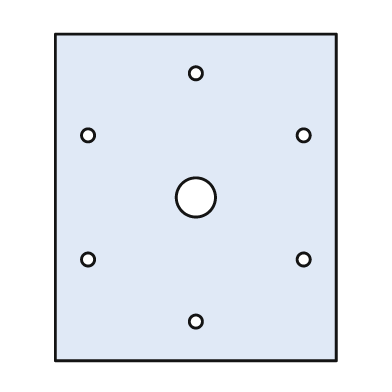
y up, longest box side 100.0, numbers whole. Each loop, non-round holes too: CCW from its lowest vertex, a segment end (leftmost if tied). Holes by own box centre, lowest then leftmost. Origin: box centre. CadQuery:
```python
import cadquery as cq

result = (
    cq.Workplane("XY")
    .moveTo(-43.0, -50.0)
    .lineTo(43.0, -50.0)
    .lineTo(43.0, 50.0)
    .lineTo(-43.0, 50.0)
    .close()
    .moveTo(0.0, -38.0)
    .circle(2.0)
    .moveTo(-33.0, -19.0)
    .circle(2.0)
    .moveTo(33.0, -19.0)
    .circle(2.0)
    .moveTo(0.0, 0.0)
    .circle(6.0)
    .moveTo(-33.0, 19.0)
    .circle(2.0)
    .moveTo(33.0, 19.0)
    .circle(2.0)
    .moveTo(0.0, 38.0)
    .circle(2.0)
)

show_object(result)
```